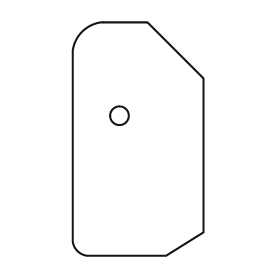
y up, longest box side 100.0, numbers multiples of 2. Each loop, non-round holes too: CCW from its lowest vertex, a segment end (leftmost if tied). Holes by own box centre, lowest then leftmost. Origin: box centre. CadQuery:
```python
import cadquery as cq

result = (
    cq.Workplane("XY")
    .moveTo(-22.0, -50.0)
    .lineTo(12.0, -50.0)
    .lineTo(28.0, -40.0)
    .lineTo(28.0, 26.0)
    .lineTo(4.0, 50.0)
    .lineTo(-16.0, 50.0)
    .threePointArc((-24.0, 46.0), (-28.0, 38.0))
    .lineTo(-28.0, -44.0)
    .threePointArc((-26.0, -48.0), (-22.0, -50.0))
    .close()
    .moveTo(-8.0, 10.0)
    .circle(4.0)
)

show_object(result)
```